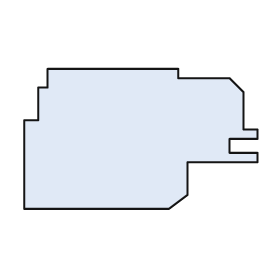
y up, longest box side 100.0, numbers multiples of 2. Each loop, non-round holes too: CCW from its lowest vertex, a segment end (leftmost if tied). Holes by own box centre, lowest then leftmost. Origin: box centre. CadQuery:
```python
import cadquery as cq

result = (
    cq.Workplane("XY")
    .moveTo(-50.0, -30.0)
    .lineTo(12.0, -30.0)
    .lineTo(20.0, -24.0)
    .lineTo(20.0, -10.0)
    .lineTo(50.0, -10.0)
    .lineTo(50.0, -6.0)
    .lineTo(38.0, -6.0)
    .lineTo(38.0, 0.0)
    .lineTo(50.0, 0.0)
    .lineTo(50.0, 4.0)
    .lineTo(44.0, 4.0)
    .lineTo(44.0, 20.0)
    .lineTo(38.0, 26.0)
    .lineTo(16.0, 26.0)
    .lineTo(16.0, 30.0)
    .lineTo(-40.0, 30.0)
    .lineTo(-40.0, 22.0)
    .lineTo(-44.0, 22.0)
    .lineTo(-44.0, 8.0)
    .lineTo(-50.0, 8.0)
    .close()
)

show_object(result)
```